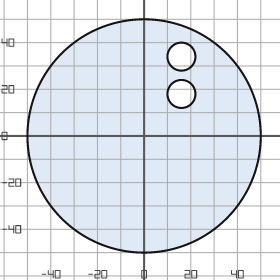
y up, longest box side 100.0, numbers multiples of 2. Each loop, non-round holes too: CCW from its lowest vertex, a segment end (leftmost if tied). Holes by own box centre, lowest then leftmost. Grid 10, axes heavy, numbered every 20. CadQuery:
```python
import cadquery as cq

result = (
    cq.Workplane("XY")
    .moveTo(0.0, 0.0)
    .circle(50.0)
    .moveTo(16.0, 18.0)
    .circle(6.0)
    .moveTo(16.0, 34.0)
    .circle(6.0)
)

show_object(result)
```